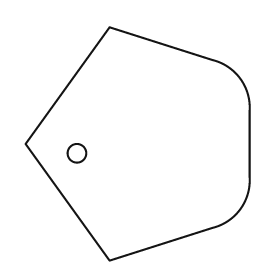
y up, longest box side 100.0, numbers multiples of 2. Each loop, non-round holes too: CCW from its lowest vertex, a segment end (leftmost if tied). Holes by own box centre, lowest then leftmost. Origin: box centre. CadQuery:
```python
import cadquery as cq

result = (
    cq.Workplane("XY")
    .moveTo(-12.0, -50.0)
    .lineTo(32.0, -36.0)
    .threePointArc((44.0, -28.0), (48.0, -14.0))
    .lineTo(48.0, 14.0)
    .threePointArc((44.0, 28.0), (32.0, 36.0))
    .lineTo(-12.0, 50.0)
    .lineTo(-48.0, 0.0)
    .close()
    .moveTo(-26.0, -4.0)
    .circle(4.0)
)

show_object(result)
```